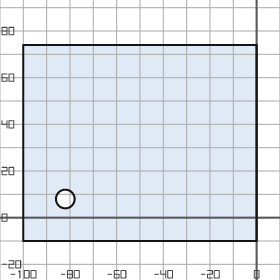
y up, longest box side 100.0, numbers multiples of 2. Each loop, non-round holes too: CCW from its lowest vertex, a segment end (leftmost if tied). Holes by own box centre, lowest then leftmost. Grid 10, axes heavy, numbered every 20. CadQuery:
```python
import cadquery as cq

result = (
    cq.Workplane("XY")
    .moveTo(-100.0, -10.0)
    .lineTo(0.0, -10.0)
    .lineTo(0.0, 74.0)
    .lineTo(-100.0, 74.0)
    .close()
    .moveTo(-82.0, 8.0)
    .circle(4.0)
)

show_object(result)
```